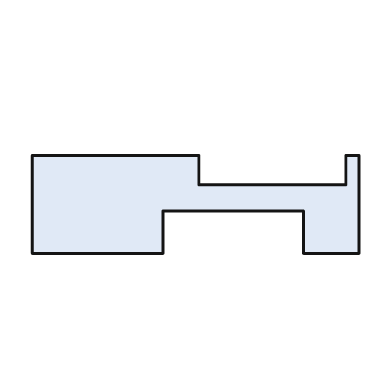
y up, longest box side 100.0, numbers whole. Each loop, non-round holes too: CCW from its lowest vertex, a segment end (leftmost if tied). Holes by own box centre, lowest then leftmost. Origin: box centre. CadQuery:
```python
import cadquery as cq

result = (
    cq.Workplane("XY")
    .moveTo(-50.0, -15.0)
    .lineTo(-10.0, -15.0)
    .lineTo(-10.0, -2.0)
    .lineTo(33.0, -2.0)
    .lineTo(33.0, -15.0)
    .lineTo(50.0, -15.0)
    .lineTo(50.0, 15.0)
    .lineTo(46.0, 15.0)
    .lineTo(46.0, 6.0)
    .lineTo(1.0, 6.0)
    .lineTo(1.0, 15.0)
    .lineTo(-50.0, 15.0)
    .close()
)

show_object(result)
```